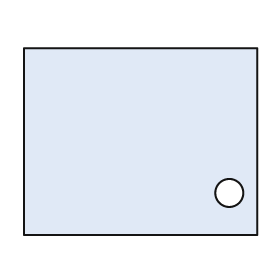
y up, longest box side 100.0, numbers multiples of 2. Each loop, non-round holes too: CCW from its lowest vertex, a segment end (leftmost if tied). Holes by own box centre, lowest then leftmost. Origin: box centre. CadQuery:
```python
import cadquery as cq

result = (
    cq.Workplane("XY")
    .moveTo(-50.0, -40.0)
    .lineTo(50.0, -40.0)
    .lineTo(50.0, 40.0)
    .lineTo(-50.0, 40.0)
    .close()
    .moveTo(38.0, -22.0)
    .circle(6.0)
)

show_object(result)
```